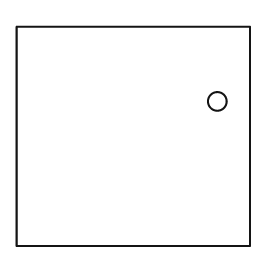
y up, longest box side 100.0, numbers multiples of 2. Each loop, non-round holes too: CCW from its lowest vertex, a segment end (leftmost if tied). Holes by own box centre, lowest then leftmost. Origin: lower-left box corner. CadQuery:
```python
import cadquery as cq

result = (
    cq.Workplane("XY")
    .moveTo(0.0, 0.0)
    .lineTo(100.0, 0.0)
    .lineTo(100.0, 94.0)
    .lineTo(0.0, 94.0)
    .close()
    .moveTo(86.0, 62.0)
    .circle(4.0)
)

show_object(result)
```